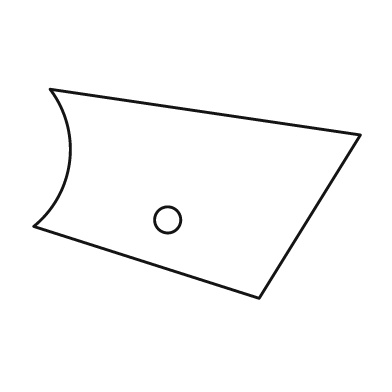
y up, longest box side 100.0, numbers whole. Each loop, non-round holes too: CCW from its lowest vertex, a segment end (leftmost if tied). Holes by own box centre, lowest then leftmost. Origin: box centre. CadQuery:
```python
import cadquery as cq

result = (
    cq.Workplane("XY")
    .moveTo(19.0, -32.0)
    .lineTo(50.0, 18.0)
    .lineTo(-45.0, 32.0)
    .threePointArc((-39.0, 10.0), (-50.0, -10.0))
    .close()
    .moveTo(-9.0, -8.0)
    .circle(4.0)
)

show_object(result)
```